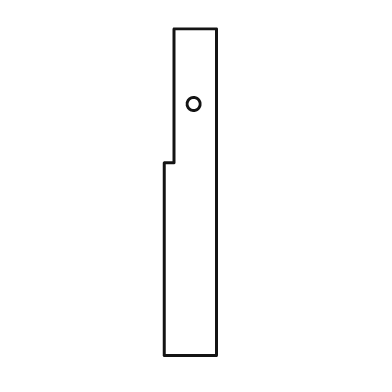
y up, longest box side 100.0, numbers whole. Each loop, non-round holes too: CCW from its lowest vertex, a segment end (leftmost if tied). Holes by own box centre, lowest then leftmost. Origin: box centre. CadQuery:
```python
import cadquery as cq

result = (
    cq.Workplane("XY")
    .moveTo(-8.0, -50.0)
    .lineTo(8.0, -50.0)
    .lineTo(8.0, 50.0)
    .lineTo(-5.0, 50.0)
    .lineTo(-5.0, 9.0)
    .lineTo(-8.0, 9.0)
    .close()
    .moveTo(1.0, 27.0)
    .circle(2.0)
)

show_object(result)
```